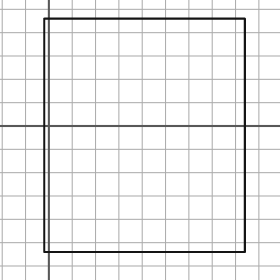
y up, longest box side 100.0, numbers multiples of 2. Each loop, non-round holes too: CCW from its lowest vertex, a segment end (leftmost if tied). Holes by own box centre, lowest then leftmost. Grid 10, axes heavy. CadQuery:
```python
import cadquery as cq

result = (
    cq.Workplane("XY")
    .moveTo(-2.0, -54.0)
    .lineTo(84.0, -54.0)
    .lineTo(84.0, 46.0)
    .lineTo(-2.0, 46.0)
    .close()
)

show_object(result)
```